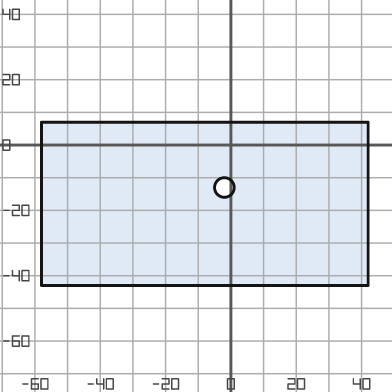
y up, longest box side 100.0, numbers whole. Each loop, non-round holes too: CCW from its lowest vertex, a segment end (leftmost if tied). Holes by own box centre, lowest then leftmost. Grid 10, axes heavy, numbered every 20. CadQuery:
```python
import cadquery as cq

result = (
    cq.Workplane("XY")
    .moveTo(-58.0, -43.0)
    .lineTo(42.0, -43.0)
    .lineTo(42.0, 7.0)
    .lineTo(-58.0, 7.0)
    .close()
    .moveTo(-2.0, -13.0)
    .circle(3.0)
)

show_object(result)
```